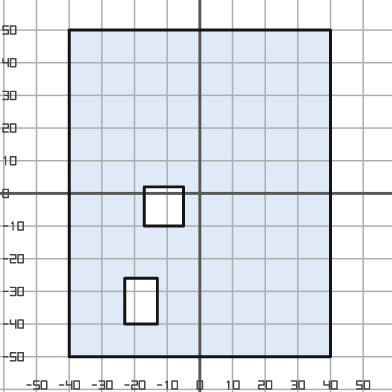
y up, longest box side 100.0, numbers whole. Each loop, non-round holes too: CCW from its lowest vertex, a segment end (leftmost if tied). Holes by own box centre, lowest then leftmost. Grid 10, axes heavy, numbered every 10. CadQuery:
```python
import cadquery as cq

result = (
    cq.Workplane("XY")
    .moveTo(-40.0, -50.0)
    .lineTo(40.0, -50.0)
    .lineTo(40.0, 50.0)
    .lineTo(-40.0, 50.0)
    .close()
    .moveTo(-23.0, -40.0)
    .lineTo(-13.0, -40.0)
    .lineTo(-13.0, -26.0)
    .lineTo(-23.0, -26.0)
    .close()
    .moveTo(-17.0, -10.0)
    .lineTo(-5.0, -10.0)
    .lineTo(-5.0, 2.0)
    .lineTo(-17.0, 2.0)
    .close()
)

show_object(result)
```